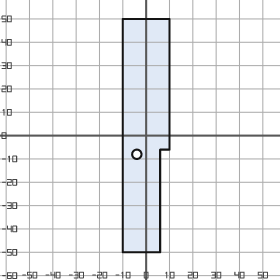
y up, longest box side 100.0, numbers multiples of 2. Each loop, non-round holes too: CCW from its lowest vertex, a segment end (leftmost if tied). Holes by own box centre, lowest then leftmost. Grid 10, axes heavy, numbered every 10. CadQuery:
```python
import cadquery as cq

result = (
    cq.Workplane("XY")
    .moveTo(-10.0, -50.0)
    .lineTo(6.0, -50.0)
    .lineTo(6.0, -6.0)
    .lineTo(10.0, -6.0)
    .lineTo(10.0, 50.0)
    .lineTo(-10.0, 50.0)
    .close()
    .moveTo(-4.0, -8.0)
    .circle(2.0)
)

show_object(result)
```